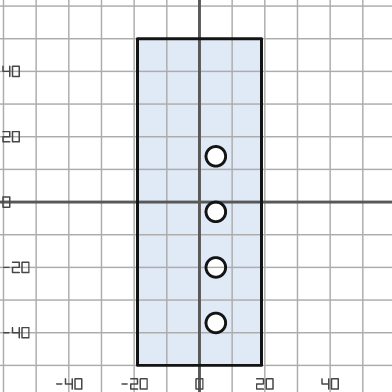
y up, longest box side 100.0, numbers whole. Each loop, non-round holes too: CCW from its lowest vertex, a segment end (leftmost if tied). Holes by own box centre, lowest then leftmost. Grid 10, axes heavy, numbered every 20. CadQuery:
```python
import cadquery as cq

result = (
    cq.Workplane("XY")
    .moveTo(-19.0, -50.0)
    .lineTo(19.0, -50.0)
    .lineTo(19.0, 50.0)
    .lineTo(-19.0, 50.0)
    .close()
    .moveTo(5.0, -37.0)
    .circle(3.0)
    .moveTo(5.0, -20.0)
    .circle(3.0)
    .moveTo(5.0, -3.0)
    .circle(3.0)
    .moveTo(5.0, 14.0)
    .circle(3.0)
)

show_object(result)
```